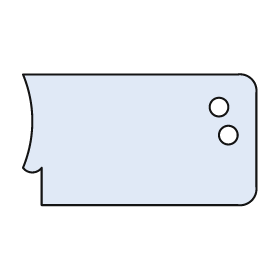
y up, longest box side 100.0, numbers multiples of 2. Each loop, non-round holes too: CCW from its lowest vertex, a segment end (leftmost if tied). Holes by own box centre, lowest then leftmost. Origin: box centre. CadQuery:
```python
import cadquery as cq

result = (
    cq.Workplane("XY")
    .moveTo(-42.0, -28.0)
    .lineTo(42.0, -28.0)
    .threePointArc((48.0, -26.0), (50.0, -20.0))
    .lineTo(50.0, 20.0)
    .threePointArc((48.0, 26.0), (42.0, 28.0))
    .lineTo(-50.0, 28.0)
    .threePointArc((-46.0, 8.0), (-50.0, -12.0))
    .threePointArc((-46.0, -14.0), (-42.0, -12.0))
    .close()
    .moveTo(38.0, 2.0)
    .circle(4.0)
    .moveTo(34.0, 14.0)
    .circle(4.0)
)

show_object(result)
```